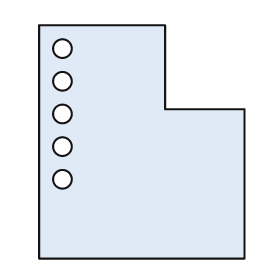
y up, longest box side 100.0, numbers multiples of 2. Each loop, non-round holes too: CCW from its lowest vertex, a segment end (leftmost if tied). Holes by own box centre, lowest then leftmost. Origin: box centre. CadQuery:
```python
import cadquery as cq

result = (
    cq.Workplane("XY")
    .moveTo(-44.0, -50.0)
    .lineTo(44.0, -50.0)
    .lineTo(44.0, 14.0)
    .lineTo(10.0, 14.0)
    .lineTo(10.0, 50.0)
    .lineTo(-44.0, 50.0)
    .close()
    .moveTo(-34.0, -16.0)
    .circle(4.0)
    .moveTo(-34.0, -2.0)
    .circle(4.0)
    .moveTo(-34.0, 12.0)
    .circle(4.0)
    .moveTo(-34.0, 26.0)
    .circle(4.0)
    .moveTo(-34.0, 40.0)
    .circle(4.0)
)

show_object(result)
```